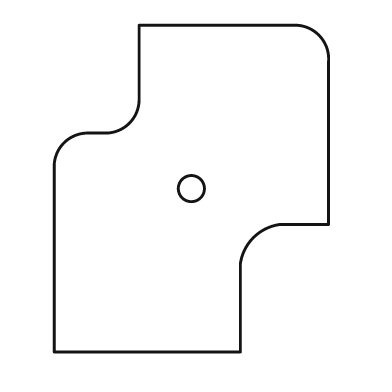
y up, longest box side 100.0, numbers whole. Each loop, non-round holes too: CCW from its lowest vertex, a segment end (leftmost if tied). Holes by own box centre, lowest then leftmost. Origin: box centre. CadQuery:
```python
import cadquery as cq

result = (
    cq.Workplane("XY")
    .moveTo(-42.0, -50.0)
    .lineTo(15.0, -50.0)
    .lineTo(15.0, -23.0)
    .threePointArc((19.0, -15.0), (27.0, -11.0))
    .lineTo(42.0, -11.0)
    .lineTo(42.0, 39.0)
    .threePointArc((39.0, 47.0), (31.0, 50.0))
    .lineTo(-16.0, 50.0)
    .lineTo(-16.0, 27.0)
    .threePointArc((-19.0, 20.0), (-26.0, 17.0))
    .lineTo(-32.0, 17.0)
    .threePointArc((-39.0, 14.0), (-42.0, 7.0))
    .close()
    .moveTo(0.0, 0.0)
    .circle(4.0)
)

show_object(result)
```